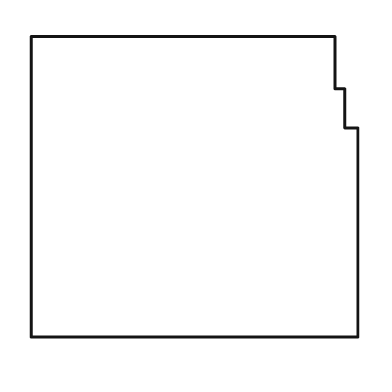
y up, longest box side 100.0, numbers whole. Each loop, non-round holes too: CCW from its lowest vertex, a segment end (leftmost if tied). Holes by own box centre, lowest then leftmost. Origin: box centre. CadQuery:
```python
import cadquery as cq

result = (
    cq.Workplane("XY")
    .moveTo(-50.0, -46.0)
    .lineTo(50.0, -46.0)
    .lineTo(50.0, 18.0)
    .lineTo(46.0, 18.0)
    .lineTo(46.0, 30.0)
    .lineTo(43.0, 30.0)
    .lineTo(43.0, 46.0)
    .lineTo(-50.0, 46.0)
    .close()
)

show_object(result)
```